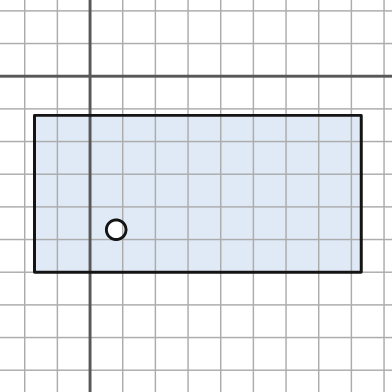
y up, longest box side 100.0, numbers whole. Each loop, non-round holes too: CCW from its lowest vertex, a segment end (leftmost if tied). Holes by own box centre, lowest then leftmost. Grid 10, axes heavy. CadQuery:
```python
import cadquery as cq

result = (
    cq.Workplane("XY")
    .moveTo(-17.0, -60.0)
    .lineTo(83.0, -60.0)
    .lineTo(83.0, -12.0)
    .lineTo(-17.0, -12.0)
    .close()
    .moveTo(8.0, -47.0)
    .circle(3.0)
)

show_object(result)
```